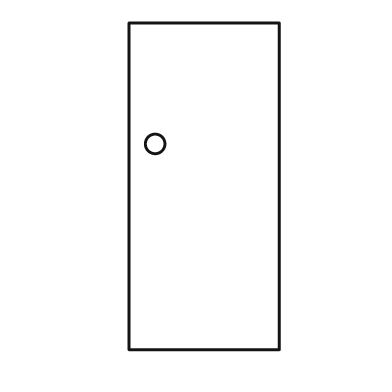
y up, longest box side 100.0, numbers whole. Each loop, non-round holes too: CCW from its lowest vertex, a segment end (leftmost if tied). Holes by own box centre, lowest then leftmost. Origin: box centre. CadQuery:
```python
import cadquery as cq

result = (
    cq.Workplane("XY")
    .moveTo(-23.0, -50.0)
    .lineTo(23.0, -50.0)
    .lineTo(23.0, 50.0)
    .lineTo(-23.0, 50.0)
    .close()
    .moveTo(-15.0, 13.0)
    .circle(3.0)
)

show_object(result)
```